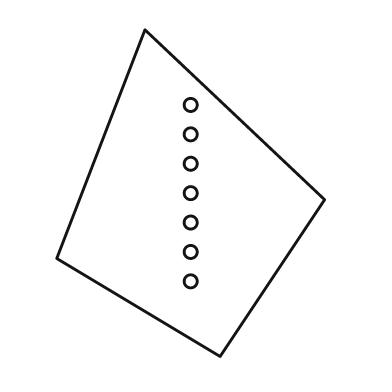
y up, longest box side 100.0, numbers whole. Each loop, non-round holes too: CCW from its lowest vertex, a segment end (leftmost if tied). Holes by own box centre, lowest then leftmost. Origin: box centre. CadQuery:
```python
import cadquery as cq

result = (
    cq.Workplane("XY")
    .moveTo(9.0, -50.0)
    .lineTo(41.0, -2.0)
    .lineTo(-14.0, 50.0)
    .lineTo(-41.0, -20.0)
    .close()
    .moveTo(0.0, -27.0)
    .circle(2.0)
    .moveTo(0.0, -18.0)
    .circle(2.0)
    .moveTo(0.0, -9.0)
    .circle(2.0)
    .moveTo(0.0, 0.0)
    .circle(2.0)
    .moveTo(0.0, 9.0)
    .circle(2.0)
    .moveTo(0.0, 18.0)
    .circle(2.0)
    .moveTo(0.0, 27.0)
    .circle(2.0)
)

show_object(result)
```